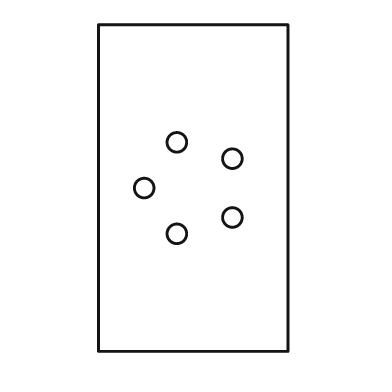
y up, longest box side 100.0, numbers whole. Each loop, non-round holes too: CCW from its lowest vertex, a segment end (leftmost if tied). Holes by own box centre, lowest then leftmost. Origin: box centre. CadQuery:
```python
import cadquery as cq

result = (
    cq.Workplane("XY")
    .moveTo(-29.0, -50.0)
    .lineTo(29.0, -50.0)
    .lineTo(29.0, 50.0)
    .lineTo(-29.0, 50.0)
    .close()
    .moveTo(-5.0, -14.0)
    .circle(3.0)
    .moveTo(12.0, -9.0)
    .circle(3.0)
    .moveTo(-15.0, 0.0)
    .circle(3.0)
    .moveTo(12.0, 9.0)
    .circle(3.0)
    .moveTo(-5.0, 14.0)
    .circle(3.0)
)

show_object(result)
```